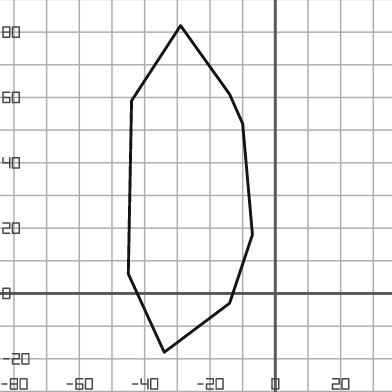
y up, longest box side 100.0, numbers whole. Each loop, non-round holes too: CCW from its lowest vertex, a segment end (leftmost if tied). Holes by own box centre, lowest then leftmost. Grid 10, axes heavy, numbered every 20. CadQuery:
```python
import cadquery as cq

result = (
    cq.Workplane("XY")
    .moveTo(-34.0, -18.0)
    .lineTo(-14.0, -3.0)
    .lineTo(-7.0, 18.0)
    .lineTo(-10.0, 52.0)
    .lineTo(-14.0, 61.0)
    .lineTo(-29.0, 82.0)
    .lineTo(-44.0, 59.0)
    .lineTo(-45.0, 6.0)
    .close()
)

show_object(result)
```